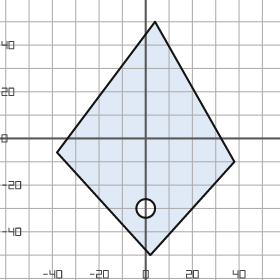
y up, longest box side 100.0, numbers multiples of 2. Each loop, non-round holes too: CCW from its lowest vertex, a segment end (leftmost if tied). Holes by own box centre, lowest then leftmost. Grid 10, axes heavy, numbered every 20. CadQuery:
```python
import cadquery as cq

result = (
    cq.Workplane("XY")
    .moveTo(2.0, -50.0)
    .lineTo(38.0, -10.0)
    .lineTo(4.0, 50.0)
    .lineTo(-38.0, -6.0)
    .close()
    .moveTo(0.0, -30.0)
    .circle(4.0)
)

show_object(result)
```